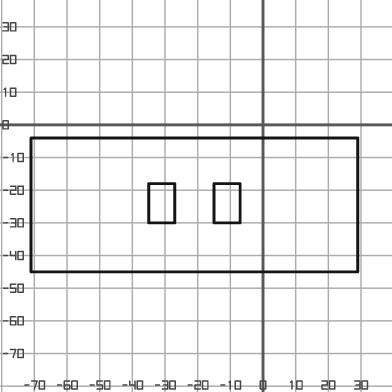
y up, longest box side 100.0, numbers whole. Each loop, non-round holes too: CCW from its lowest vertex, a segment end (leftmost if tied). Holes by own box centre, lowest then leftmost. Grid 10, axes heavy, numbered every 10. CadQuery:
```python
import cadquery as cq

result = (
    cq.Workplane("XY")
    .moveTo(-71.0, -45.0)
    .lineTo(29.0, -45.0)
    .lineTo(29.0, -4.0)
    .lineTo(-71.0, -4.0)
    .close()
    .moveTo(-35.0, -30.0)
    .lineTo(-27.0, -30.0)
    .lineTo(-27.0, -18.0)
    .lineTo(-35.0, -18.0)
    .close()
    .moveTo(-15.0, -30.0)
    .lineTo(-7.0, -30.0)
    .lineTo(-7.0, -18.0)
    .lineTo(-15.0, -18.0)
    .close()
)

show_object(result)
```